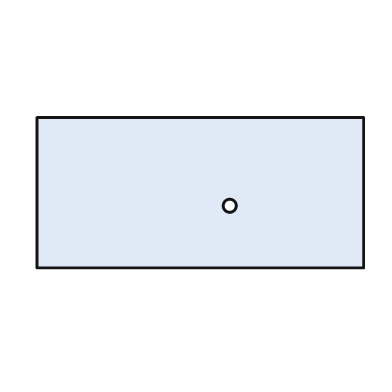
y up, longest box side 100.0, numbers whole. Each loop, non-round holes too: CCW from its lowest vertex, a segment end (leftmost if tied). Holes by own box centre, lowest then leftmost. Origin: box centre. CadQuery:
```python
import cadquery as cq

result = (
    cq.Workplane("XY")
    .moveTo(-50.0, -23.0)
    .lineTo(50.0, -23.0)
    .lineTo(50.0, 23.0)
    .lineTo(-50.0, 23.0)
    .close()
    .moveTo(9.0, -4.0)
    .circle(2.0)
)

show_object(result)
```